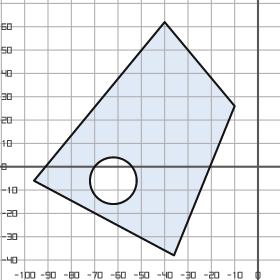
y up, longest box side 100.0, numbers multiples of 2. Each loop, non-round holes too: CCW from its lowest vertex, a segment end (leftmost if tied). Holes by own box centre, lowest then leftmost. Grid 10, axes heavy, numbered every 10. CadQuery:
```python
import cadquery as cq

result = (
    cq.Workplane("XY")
    .moveTo(-36.0, -38.0)
    .lineTo(-10.0, 26.0)
    .lineTo(-40.0, 62.0)
    .lineTo(-96.0, -6.0)
    .close()
    .moveTo(-62.0, -6.0)
    .circle(10.0)
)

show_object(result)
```